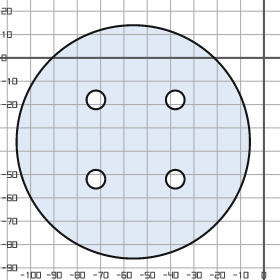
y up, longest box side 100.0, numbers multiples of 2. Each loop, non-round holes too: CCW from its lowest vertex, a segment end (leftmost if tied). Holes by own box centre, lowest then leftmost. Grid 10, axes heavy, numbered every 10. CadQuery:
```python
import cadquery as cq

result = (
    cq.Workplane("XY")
    .moveTo(-56.0, -36.0)
    .circle(50.0)
    .moveTo(-72.0, -52.0)
    .circle(4.0)
    .moveTo(-38.0, -52.0)
    .circle(4.0)
    .moveTo(-72.0, -18.0)
    .circle(4.0)
    .moveTo(-38.0, -18.0)
    .circle(4.0)
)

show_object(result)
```